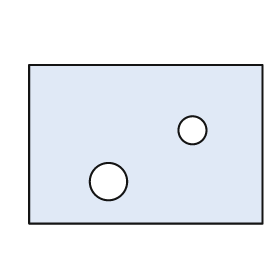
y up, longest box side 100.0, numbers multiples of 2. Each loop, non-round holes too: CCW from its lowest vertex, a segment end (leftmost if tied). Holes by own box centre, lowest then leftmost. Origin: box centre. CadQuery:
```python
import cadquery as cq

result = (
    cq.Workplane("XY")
    .moveTo(-50.0, -34.0)
    .lineTo(50.0, -34.0)
    .lineTo(50.0, 34.0)
    .lineTo(-50.0, 34.0)
    .close()
    .moveTo(-16.0, -16.0)
    .circle(8.0)
    .moveTo(20.0, 6.0)
    .circle(6.0)
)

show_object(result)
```